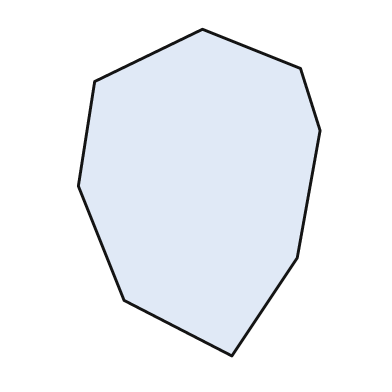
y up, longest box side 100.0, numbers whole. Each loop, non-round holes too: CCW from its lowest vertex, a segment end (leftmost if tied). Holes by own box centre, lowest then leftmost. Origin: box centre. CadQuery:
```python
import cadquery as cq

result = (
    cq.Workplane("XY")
    .moveTo(10.0, -50.0)
    .lineTo(30.0, -20.0)
    .lineTo(37.0, 19.0)
    .lineTo(31.0, 38.0)
    .lineTo(1.0, 50.0)
    .lineTo(-32.0, 34.0)
    .lineTo(-37.0, 2.0)
    .lineTo(-23.0, -33.0)
    .close()
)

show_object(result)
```